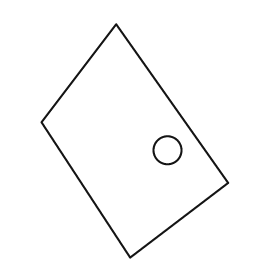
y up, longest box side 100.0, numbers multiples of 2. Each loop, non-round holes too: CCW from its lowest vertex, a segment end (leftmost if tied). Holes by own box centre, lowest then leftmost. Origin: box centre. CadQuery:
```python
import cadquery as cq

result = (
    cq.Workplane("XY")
    .moveTo(-2.0, -50.0)
    .lineTo(40.0, -18.0)
    .lineTo(-8.0, 50.0)
    .lineTo(-40.0, 8.0)
    .close()
    .moveTo(14.0, -4.0)
    .circle(6.0)
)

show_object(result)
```